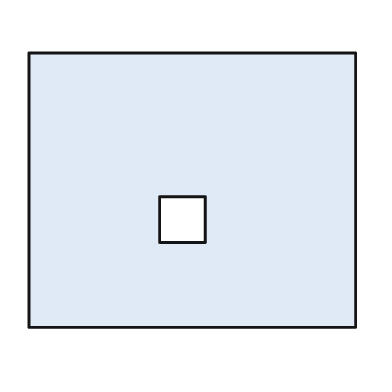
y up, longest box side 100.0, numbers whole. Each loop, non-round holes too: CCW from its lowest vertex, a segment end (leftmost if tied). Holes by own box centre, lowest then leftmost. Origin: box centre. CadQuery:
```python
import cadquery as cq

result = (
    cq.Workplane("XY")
    .moveTo(-50.0, -42.0)
    .lineTo(50.0, -42.0)
    .lineTo(50.0, 42.0)
    .lineTo(-50.0, 42.0)
    .close()
    .moveTo(-10.0, -16.0)
    .lineTo(4.0, -16.0)
    .lineTo(4.0, -2.0)
    .lineTo(-10.0, -2.0)
    .close()
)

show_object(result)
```